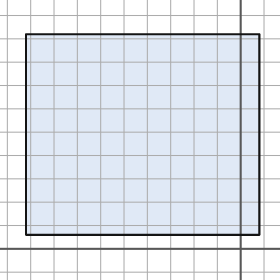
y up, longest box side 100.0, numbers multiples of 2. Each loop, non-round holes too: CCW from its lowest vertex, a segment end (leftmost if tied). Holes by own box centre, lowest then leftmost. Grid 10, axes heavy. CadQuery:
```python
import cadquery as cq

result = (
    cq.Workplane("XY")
    .moveTo(-92.0, 6.0)
    .lineTo(8.0, 6.0)
    .lineTo(8.0, 92.0)
    .lineTo(-92.0, 92.0)
    .close()
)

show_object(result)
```